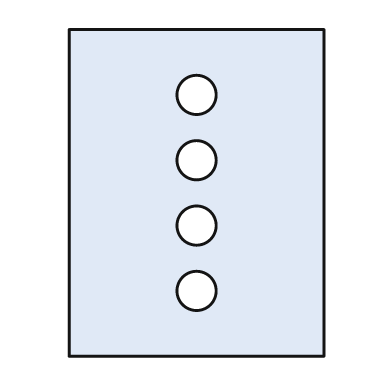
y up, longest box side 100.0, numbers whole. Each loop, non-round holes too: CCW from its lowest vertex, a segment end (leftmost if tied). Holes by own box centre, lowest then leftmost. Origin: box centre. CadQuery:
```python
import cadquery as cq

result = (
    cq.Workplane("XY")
    .moveTo(-39.0, -50.0)
    .lineTo(39.0, -50.0)
    .lineTo(39.0, 50.0)
    .lineTo(-39.0, 50.0)
    .close()
    .moveTo(0.0, -30.0)
    .circle(6.0)
    .moveTo(0.0, -10.0)
    .circle(6.0)
    .moveTo(0.0, 10.0)
    .circle(6.0)
    .moveTo(0.0, 30.0)
    .circle(6.0)
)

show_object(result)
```